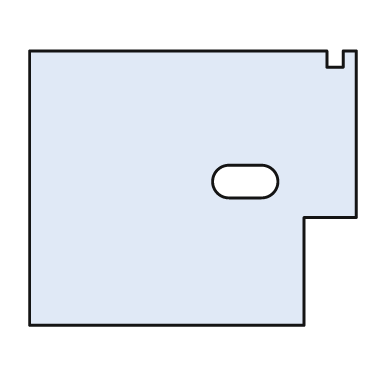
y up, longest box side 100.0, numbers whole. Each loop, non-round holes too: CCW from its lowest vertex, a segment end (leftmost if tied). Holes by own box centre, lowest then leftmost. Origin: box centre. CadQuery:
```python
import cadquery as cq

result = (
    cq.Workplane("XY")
    .moveTo(-50.0, -42.0)
    .lineTo(34.0, -42.0)
    .lineTo(34.0, -9.0)
    .lineTo(50.0, -9.0)
    .lineTo(50.0, 42.0)
    .lineTo(46.0, 42.0)
    .lineTo(46.0, 37.0)
    .lineTo(41.0, 37.0)
    .lineTo(41.0, 42.0)
    .lineTo(-50.0, 42.0)
    .close()
    .moveTo(11.0, -3.0)
    .lineTo(21.0, -3.0)
    .threePointArc((26.0, 2.0), (21.0, 7.0))
    .lineTo(11.0, 7.0)
    .threePointArc((6.0, 2.0), (11.0, -3.0))
    .close()
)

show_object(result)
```